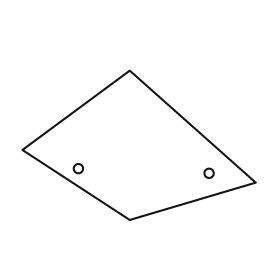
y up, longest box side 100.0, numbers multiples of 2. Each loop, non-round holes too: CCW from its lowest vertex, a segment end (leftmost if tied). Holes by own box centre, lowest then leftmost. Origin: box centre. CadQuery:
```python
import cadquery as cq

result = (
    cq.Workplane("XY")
    .moveTo(-4.0, -32.0)
    .lineTo(50.0, -16.0)
    .lineTo(-4.0, 32.0)
    .lineTo(-50.0, -2.0)
    .close()
    .moveTo(30.0, -12.0)
    .circle(2.0)
    .moveTo(-26.0, -10.0)
    .circle(2.0)
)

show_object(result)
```